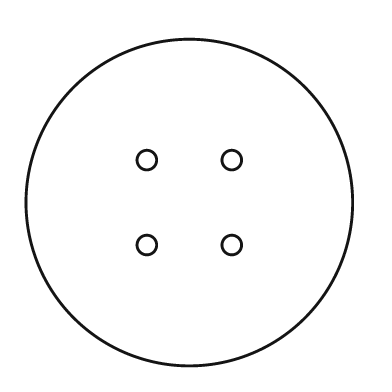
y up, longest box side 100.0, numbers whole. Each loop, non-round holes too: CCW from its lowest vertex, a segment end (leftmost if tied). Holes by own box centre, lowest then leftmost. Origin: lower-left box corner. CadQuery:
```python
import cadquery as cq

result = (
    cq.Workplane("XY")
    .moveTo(50.0, 50.0)
    .circle(50.0)
    .moveTo(37.0, 37.0)
    .circle(3.0)
    .moveTo(63.0, 37.0)
    .circle(3.0)
    .moveTo(37.0, 63.0)
    .circle(3.0)
    .moveTo(63.0, 63.0)
    .circle(3.0)
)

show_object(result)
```